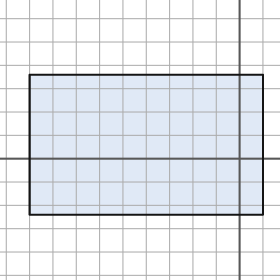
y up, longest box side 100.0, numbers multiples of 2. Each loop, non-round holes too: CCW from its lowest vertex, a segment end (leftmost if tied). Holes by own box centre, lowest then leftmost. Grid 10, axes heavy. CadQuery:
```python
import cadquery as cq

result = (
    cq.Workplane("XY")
    .moveTo(-90.0, -24.0)
    .lineTo(10.0, -24.0)
    .lineTo(10.0, 36.0)
    .lineTo(-90.0, 36.0)
    .close()
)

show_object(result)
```